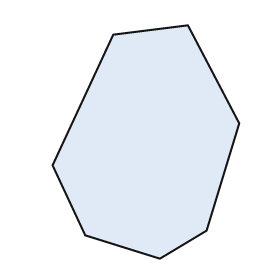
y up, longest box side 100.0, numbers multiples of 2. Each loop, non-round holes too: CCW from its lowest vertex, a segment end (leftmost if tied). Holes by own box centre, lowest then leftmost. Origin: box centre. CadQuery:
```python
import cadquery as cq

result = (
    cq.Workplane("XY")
    .moveTo(6.0, -50.0)
    .lineTo(26.0, -38.0)
    .lineTo(40.0, 8.0)
    .lineTo(18.0, 50.0)
    .lineTo(-14.0, 46.0)
    .lineTo(-40.0, -10.0)
    .lineTo(-26.0, -40.0)
    .close()
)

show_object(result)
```